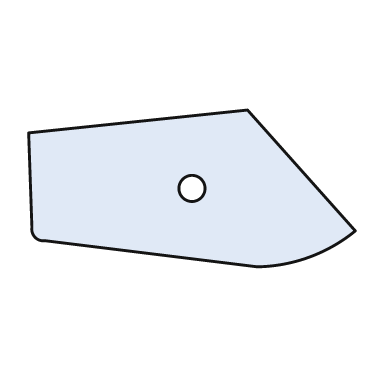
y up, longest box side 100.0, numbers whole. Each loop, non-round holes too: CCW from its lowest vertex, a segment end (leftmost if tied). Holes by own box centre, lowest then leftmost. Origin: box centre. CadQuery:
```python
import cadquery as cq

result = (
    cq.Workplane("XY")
    .moveTo(20.0, -24.0)
    .threePointArc((36.0, -21.0), (50.0, -13.0))
    .lineTo(17.0, 24.0)
    .lineTo(-50.0, 17.0)
    .lineTo(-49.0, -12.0)
    .threePointArc((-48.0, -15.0), (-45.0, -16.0))
    .close()
    .moveTo(0.0, 0.0)
    .circle(4.0)
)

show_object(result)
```